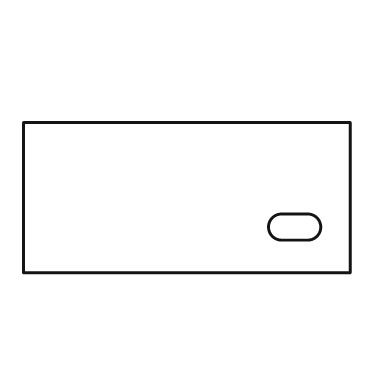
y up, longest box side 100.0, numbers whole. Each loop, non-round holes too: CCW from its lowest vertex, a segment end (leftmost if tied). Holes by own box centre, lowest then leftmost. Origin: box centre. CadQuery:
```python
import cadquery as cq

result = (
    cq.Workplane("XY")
    .moveTo(-50.0, -23.0)
    .lineTo(50.0, -23.0)
    .lineTo(50.0, 23.0)
    .lineTo(-50.0, 23.0)
    .close()
    .moveTo(29.0, -13.0)
    .lineTo(37.0, -13.0)
    .threePointArc((41.0, -9.0), (37.0, -5.0))
    .lineTo(29.0, -5.0)
    .threePointArc((25.0, -9.0), (29.0, -13.0))
    .close()
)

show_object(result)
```